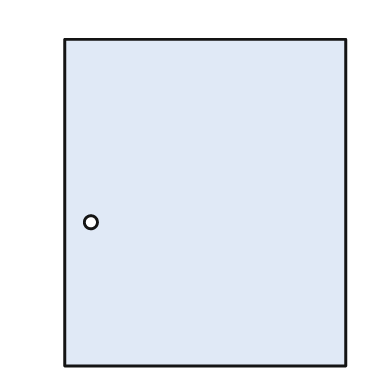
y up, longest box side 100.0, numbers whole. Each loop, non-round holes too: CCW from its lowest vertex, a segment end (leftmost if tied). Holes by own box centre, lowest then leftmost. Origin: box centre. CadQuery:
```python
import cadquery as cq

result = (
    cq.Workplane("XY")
    .moveTo(-43.0, -50.0)
    .lineTo(43.0, -50.0)
    .lineTo(43.0, 50.0)
    .lineTo(-43.0, 50.0)
    .close()
    .moveTo(-35.0, -6.0)
    .circle(2.0)
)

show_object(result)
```